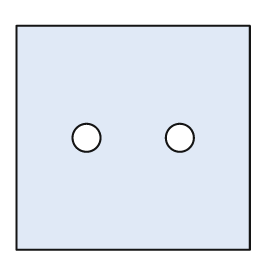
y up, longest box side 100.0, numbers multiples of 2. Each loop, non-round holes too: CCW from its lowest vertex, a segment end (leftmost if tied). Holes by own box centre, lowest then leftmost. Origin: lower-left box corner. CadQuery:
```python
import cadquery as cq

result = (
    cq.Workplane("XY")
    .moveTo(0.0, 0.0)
    .lineTo(100.0, 0.0)
    .lineTo(100.0, 96.0)
    .lineTo(0.0, 96.0)
    .close()
    .moveTo(30.0, 48.0)
    .circle(6.0)
    .moveTo(70.0, 48.0)
    .circle(6.0)
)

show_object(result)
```